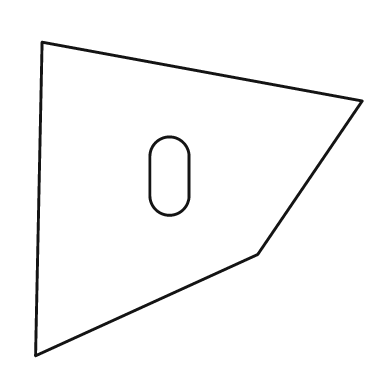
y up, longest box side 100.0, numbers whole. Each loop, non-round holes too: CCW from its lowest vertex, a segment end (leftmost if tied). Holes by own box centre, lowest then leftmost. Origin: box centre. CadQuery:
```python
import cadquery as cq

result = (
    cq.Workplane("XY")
    .moveTo(-50.0, -48.0)
    .lineTo(18.0, -17.0)
    .lineTo(50.0, 30.0)
    .lineTo(-48.0, 48.0)
    .close()
    .moveTo(-15.0, 1.0)
    .threePointArc((-9.0, -5.0), (-3.0, 1.0))
    .lineTo(-3.0, 13.0)
    .threePointArc((-9.0, 19.0), (-15.0, 13.0))
    .close()
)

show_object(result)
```